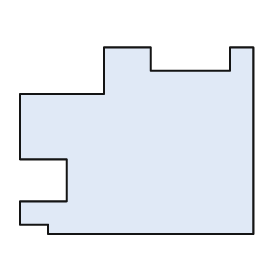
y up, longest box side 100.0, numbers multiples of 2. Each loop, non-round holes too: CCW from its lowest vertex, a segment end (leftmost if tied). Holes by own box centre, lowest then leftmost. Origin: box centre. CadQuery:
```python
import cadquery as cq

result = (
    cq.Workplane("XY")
    .moveTo(-38.0, -40.0)
    .lineTo(50.0, -40.0)
    .lineTo(50.0, 40.0)
    .lineTo(40.0, 40.0)
    .lineTo(40.0, 30.0)
    .lineTo(6.0, 30.0)
    .lineTo(6.0, 40.0)
    .lineTo(-14.0, 40.0)
    .lineTo(-14.0, 20.0)
    .lineTo(-50.0, 20.0)
    .lineTo(-50.0, -8.0)
    .lineTo(-30.0, -8.0)
    .lineTo(-30.0, -26.0)
    .lineTo(-50.0, -26.0)
    .lineTo(-50.0, -36.0)
    .lineTo(-38.0, -36.0)
    .close()
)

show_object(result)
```